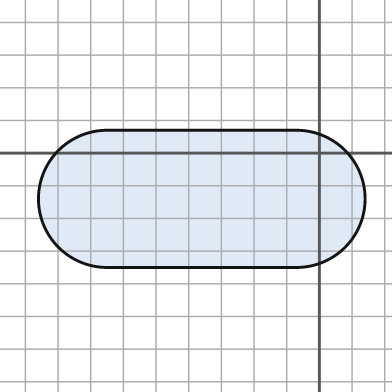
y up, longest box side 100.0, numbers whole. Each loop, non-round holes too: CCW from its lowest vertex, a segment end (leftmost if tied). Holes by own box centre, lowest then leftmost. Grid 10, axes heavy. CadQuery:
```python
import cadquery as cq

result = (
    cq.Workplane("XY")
    .moveTo(-65.0, -35.0)
    .lineTo(-7.0, -35.0)
    .threePointArc((14.0, -14.0), (-7.0, 7.0))
    .lineTo(-65.0, 7.0)
    .threePointArc((-86.0, -14.0), (-65.0, -35.0))
    .close()
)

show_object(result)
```